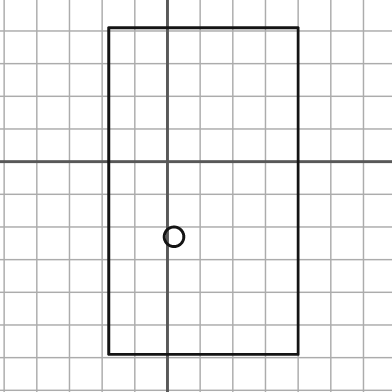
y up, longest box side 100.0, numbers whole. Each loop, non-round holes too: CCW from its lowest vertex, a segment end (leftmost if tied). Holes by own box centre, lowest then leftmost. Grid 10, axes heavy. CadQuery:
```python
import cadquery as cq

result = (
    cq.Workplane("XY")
    .moveTo(-18.0, -59.0)
    .lineTo(40.0, -59.0)
    .lineTo(40.0, 41.0)
    .lineTo(-18.0, 41.0)
    .close()
    .moveTo(2.0, -23.0)
    .circle(3.0)
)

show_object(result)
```